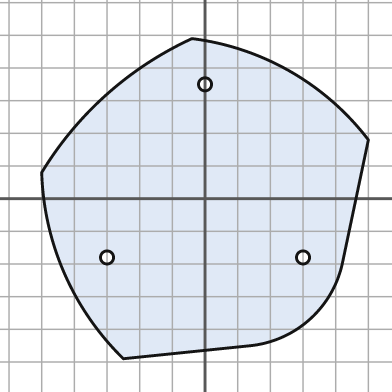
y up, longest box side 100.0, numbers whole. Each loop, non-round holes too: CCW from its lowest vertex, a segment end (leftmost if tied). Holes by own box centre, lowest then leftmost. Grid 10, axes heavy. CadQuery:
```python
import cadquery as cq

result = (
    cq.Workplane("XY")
    .moveTo(-25.0, -49.0)
    .lineTo(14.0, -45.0)
    .threePointArc((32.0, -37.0), (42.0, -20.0))
    .lineTo(50.0, 18.0)
    .threePointArc((26.0, 39.0), (-4.0, 49.0))
    .threePointArc((-30.0, 32.0), (-50.0, 8.0))
    .threePointArc((-43.0, -23.0), (-25.0, -49.0))
    .close()
    .moveTo(-30.0, -18.0)
    .circle(2.0)
    .moveTo(30.0, -18.0)
    .circle(2.0)
    .moveTo(0.0, 35.0)
    .circle(2.0)
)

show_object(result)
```